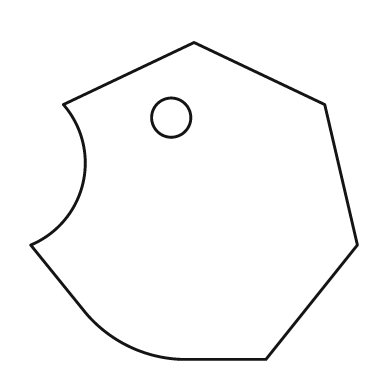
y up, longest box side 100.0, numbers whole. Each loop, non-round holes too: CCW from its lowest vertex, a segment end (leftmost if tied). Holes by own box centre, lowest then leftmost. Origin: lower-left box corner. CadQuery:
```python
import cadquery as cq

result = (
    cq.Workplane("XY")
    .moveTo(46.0, 0.0)
    .lineTo(72.0, 0.0)
    .lineTo(100.0, 35.0)
    .lineTo(90.0, 78.0)
    .lineTo(50.0, 97.0)
    .lineTo(10.0, 78.0)
    .threePointArc((16.0, 54.0), (0.0, 35.0))
    .lineTo(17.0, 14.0)
    .threePointArc((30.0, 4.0), (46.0, 0.0))
    .close()
    .moveTo(43.0, 74.0)
    .circle(6.0)
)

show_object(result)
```